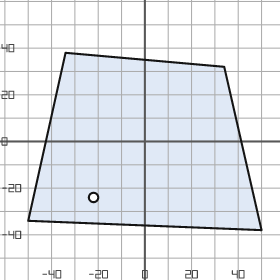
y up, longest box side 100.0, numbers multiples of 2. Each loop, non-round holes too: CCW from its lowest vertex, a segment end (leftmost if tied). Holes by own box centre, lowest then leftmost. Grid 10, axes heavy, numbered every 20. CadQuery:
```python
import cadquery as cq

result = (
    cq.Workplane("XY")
    .moveTo(50.0, -38.0)
    .lineTo(34.0, 32.0)
    .lineTo(-34.0, 38.0)
    .lineTo(-50.0, -34.0)
    .close()
    .moveTo(-22.0, -24.0)
    .circle(2.0)
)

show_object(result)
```